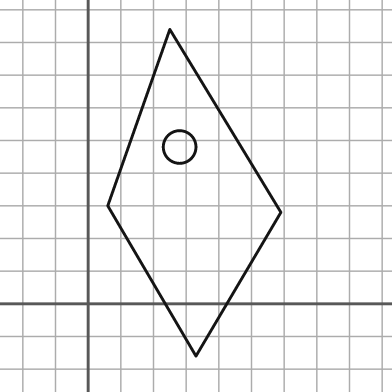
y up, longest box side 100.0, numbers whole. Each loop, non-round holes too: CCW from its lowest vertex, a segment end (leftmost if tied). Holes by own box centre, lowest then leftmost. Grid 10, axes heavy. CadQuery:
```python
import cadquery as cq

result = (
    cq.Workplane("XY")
    .moveTo(33.0, -16.0)
    .lineTo(59.0, 28.0)
    .lineTo(25.0, 84.0)
    .lineTo(6.0, 30.0)
    .close()
    .moveTo(28.0, 48.0)
    .circle(5.0)
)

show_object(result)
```